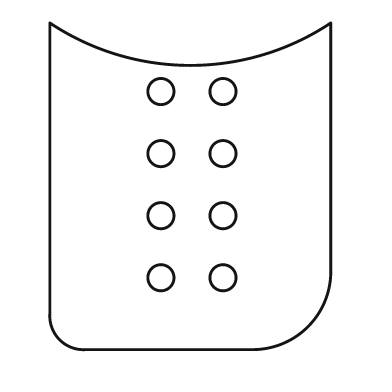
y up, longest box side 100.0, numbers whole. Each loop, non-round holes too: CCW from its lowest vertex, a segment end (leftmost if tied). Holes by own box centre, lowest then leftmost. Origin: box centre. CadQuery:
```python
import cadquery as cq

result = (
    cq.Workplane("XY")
    .moveTo(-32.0, -50.0)
    .lineTo(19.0, -50.0)
    .threePointArc((36.0, -43.0), (43.0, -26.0))
    .lineTo(43.0, 50.0)
    .threePointArc((0.0, 37.0), (-43.0, 50.0))
    .lineTo(-43.0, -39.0)
    .threePointArc((-40.0, -47.0), (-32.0, -50.0))
    .close()
    .moveTo(-9.0, -28.0)
    .circle(4.0)
    .moveTo(10.0, -28.0)
    .circle(4.0)
    .moveTo(-9.0, -9.0)
    .circle(4.0)
    .moveTo(10.0, -9.0)
    .circle(4.0)
    .moveTo(-9.0, 10.0)
    .circle(4.0)
    .moveTo(10.0, 10.0)
    .circle(4.0)
    .moveTo(-9.0, 29.0)
    .circle(4.0)
    .moveTo(10.0, 29.0)
    .circle(4.0)
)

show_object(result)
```